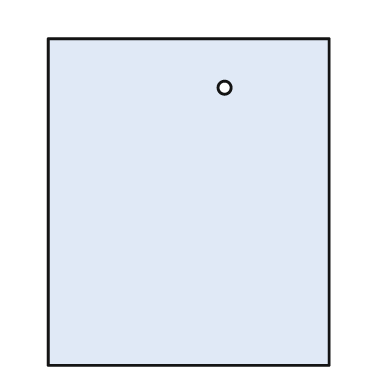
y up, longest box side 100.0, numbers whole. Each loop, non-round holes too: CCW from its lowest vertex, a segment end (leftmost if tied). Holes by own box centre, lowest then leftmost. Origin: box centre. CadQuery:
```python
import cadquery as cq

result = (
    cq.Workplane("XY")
    .moveTo(-43.0, -50.0)
    .lineTo(43.0, -50.0)
    .lineTo(43.0, 50.0)
    .lineTo(-43.0, 50.0)
    .close()
    .moveTo(11.0, 35.0)
    .circle(2.0)
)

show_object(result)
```